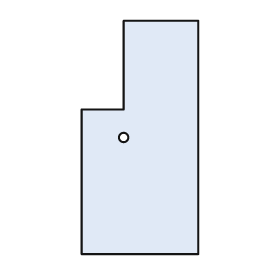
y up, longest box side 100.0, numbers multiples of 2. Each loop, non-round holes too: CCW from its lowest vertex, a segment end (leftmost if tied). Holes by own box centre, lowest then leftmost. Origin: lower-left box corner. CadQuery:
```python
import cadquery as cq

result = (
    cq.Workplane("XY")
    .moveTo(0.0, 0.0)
    .lineTo(50.0, 0.0)
    .lineTo(50.0, 100.0)
    .lineTo(18.0, 100.0)
    .lineTo(18.0, 62.0)
    .lineTo(0.0, 62.0)
    .close()
    .moveTo(18.0, 50.0)
    .circle(2.0)
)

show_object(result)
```